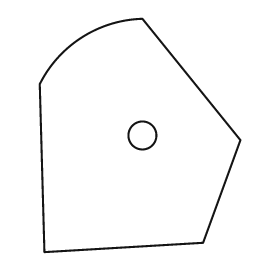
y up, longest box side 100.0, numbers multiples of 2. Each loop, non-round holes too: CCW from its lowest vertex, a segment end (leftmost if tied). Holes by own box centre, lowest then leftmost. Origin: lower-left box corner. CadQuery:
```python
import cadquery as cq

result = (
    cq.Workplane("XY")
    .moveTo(2.0, 0.0)
    .lineTo(70.0, 4.0)
    .lineTo(86.0, 48.0)
    .lineTo(44.0, 100.0)
    .threePointArc((18.0, 92.0), (0.0, 72.0))
    .close()
    .moveTo(44.0, 50.0)
    .circle(6.0)
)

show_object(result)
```